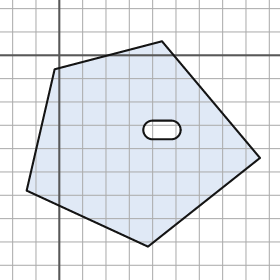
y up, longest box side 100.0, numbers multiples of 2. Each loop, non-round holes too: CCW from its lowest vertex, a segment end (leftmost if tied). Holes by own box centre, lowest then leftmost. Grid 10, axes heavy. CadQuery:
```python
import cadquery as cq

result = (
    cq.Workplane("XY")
    .moveTo(38.0, -82.0)
    .lineTo(86.0, -44.0)
    .lineTo(44.0, 6.0)
    .lineTo(-2.0, -6.0)
    .lineTo(-14.0, -58.0)
    .close()
    .moveTo(40.0, -36.0)
    .lineTo(48.0, -36.0)
    .threePointArc((52.0, -32.0), (48.0, -28.0))
    .lineTo(40.0, -28.0)
    .threePointArc((36.0, -32.0), (40.0, -36.0))
    .close()
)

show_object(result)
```